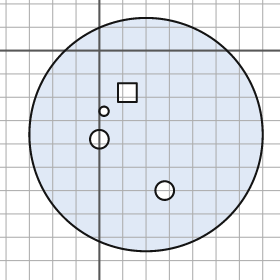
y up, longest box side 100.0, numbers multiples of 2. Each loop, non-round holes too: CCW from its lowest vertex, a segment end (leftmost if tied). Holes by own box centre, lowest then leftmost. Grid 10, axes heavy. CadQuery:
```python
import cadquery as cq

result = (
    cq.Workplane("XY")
    .moveTo(20.0, -36.0)
    .circle(50.0)
    .moveTo(28.0, -60.0)
    .circle(4.0)
    .moveTo(0.0, -38.0)
    .circle(4.0)
    .moveTo(2.0, -26.0)
    .circle(2.0)
    .moveTo(8.0, -22.0)
    .lineTo(16.0, -22.0)
    .lineTo(16.0, -14.0)
    .lineTo(8.0, -14.0)
    .close()
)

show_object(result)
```